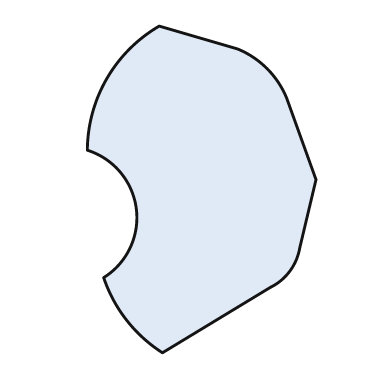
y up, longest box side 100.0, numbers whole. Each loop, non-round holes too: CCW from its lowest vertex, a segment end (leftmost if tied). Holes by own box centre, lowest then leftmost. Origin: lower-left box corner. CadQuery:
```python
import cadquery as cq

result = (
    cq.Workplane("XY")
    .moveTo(23.0, 0.0)
    .lineTo(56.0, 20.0)
    .threePointArc((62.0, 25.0), (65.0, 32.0))
    .lineTo(70.0, 53.0)
    .lineTo(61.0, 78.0)
    .threePointArc((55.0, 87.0), (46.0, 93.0))
    .lineTo(22.0, 100.0)
    .threePointArc((6.0, 84.0), (0.0, 62.0))
    .threePointArc((15.0, 44.0), (5.0, 23.0))
    .threePointArc((12.0, 10.0), (23.0, 0.0))
    .close()
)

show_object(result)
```